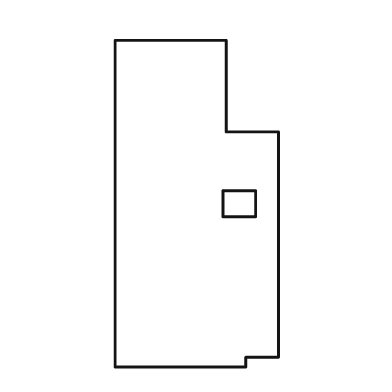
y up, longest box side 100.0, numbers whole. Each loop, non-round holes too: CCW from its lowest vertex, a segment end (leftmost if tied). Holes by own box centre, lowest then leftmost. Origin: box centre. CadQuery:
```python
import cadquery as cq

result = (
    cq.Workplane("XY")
    .moveTo(-25.0, -50.0)
    .lineTo(15.0, -50.0)
    .lineTo(15.0, -47.0)
    .lineTo(25.0, -47.0)
    .lineTo(25.0, 22.0)
    .lineTo(9.0, 22.0)
    .lineTo(9.0, 50.0)
    .lineTo(-25.0, 50.0)
    .close()
    .moveTo(8.0, -4.0)
    .lineTo(18.0, -4.0)
    .lineTo(18.0, 4.0)
    .lineTo(8.0, 4.0)
    .close()
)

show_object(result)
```